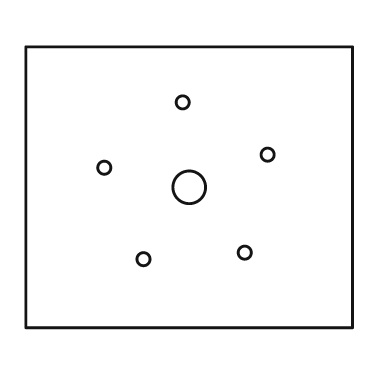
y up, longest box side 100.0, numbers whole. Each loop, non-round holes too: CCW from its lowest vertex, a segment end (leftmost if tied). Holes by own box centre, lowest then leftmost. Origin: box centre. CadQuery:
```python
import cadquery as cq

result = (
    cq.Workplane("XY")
    .moveTo(-50.0, -43.0)
    .lineTo(50.0, -43.0)
    .lineTo(50.0, 43.0)
    .lineTo(-50.0, 43.0)
    .close()
    .moveTo(-14.0, -22.0)
    .circle(2.0)
    .moveTo(17.0, -20.0)
    .circle(2.0)
    .moveTo(0.0, 0.0)
    .circle(5.0)
    .moveTo(-26.0, 6.0)
    .circle(2.0)
    .moveTo(24.0, 10.0)
    .circle(2.0)
    .moveTo(-2.0, 26.0)
    .circle(2.0)
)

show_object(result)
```